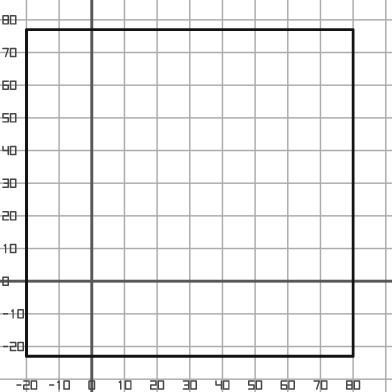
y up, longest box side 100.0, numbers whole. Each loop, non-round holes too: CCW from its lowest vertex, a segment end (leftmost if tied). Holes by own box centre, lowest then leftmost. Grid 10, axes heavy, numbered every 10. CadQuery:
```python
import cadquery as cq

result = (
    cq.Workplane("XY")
    .moveTo(-20.0, -23.0)
    .lineTo(80.0, -23.0)
    .lineTo(80.0, 77.0)
    .lineTo(-20.0, 77.0)
    .close()
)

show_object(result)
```